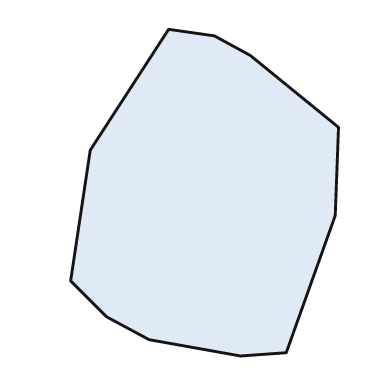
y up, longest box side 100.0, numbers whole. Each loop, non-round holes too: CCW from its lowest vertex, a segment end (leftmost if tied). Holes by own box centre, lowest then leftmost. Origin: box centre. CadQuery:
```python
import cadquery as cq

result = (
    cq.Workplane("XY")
    .moveTo(11.0, -50.0)
    .lineTo(25.0, -49.0)
    .lineTo(40.0, -7.0)
    .lineTo(41.0, 20.0)
    .lineTo(14.0, 42.0)
    .lineTo(3.0, 48.0)
    .lineTo(-11.0, 50.0)
    .lineTo(-35.0, 13.0)
    .lineTo(-41.0, -27.0)
    .lineTo(-30.0, -38.0)
    .lineTo(-17.0, -45.0)
    .close()
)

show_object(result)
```